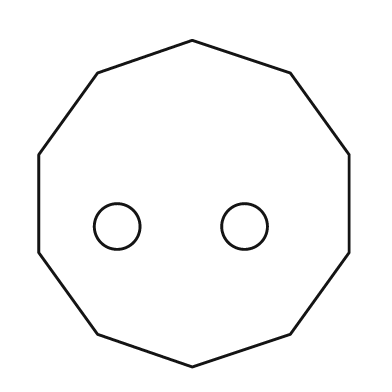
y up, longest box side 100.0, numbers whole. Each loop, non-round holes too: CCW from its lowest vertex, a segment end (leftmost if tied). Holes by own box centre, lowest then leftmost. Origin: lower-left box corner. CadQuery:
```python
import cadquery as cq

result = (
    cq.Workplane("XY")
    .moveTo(47.0, 0.0)
    .lineTo(77.0, 10.0)
    .lineTo(95.0, 35.0)
    .lineTo(95.0, 65.0)
    .lineTo(77.0, 90.0)
    .lineTo(47.0, 100.0)
    .lineTo(18.0, 90.0)
    .lineTo(0.0, 65.0)
    .lineTo(0.0, 35.0)
    .lineTo(18.0, 10.0)
    .close()
    .moveTo(24.0, 43.0)
    .circle(7.0)
    .moveTo(63.0, 43.0)
    .circle(7.0)
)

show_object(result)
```